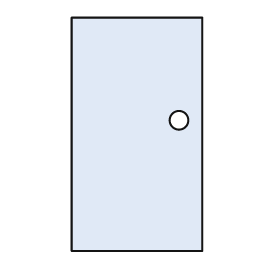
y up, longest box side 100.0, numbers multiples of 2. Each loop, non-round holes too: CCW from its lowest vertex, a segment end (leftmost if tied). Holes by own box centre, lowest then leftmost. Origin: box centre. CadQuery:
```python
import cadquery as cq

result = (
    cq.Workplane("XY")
    .moveTo(-28.0, -50.0)
    .lineTo(28.0, -50.0)
    .lineTo(28.0, 50.0)
    .lineTo(-28.0, 50.0)
    .close()
    .moveTo(18.0, 6.0)
    .circle(4.0)
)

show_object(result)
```